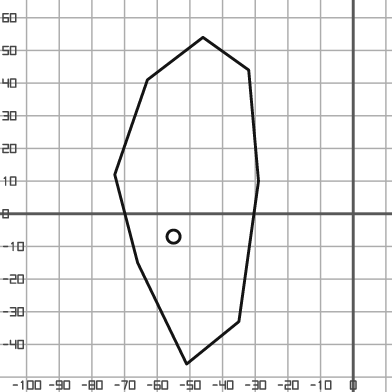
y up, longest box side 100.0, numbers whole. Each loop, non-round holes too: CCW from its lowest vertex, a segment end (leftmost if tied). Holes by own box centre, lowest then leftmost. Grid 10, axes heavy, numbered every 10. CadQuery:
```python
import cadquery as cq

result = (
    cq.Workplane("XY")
    .moveTo(-51.0, -46.0)
    .lineTo(-35.0, -33.0)
    .lineTo(-29.0, 10.0)
    .lineTo(-32.0, 44.0)
    .lineTo(-46.0, 54.0)
    .lineTo(-63.0, 41.0)
    .lineTo(-73.0, 12.0)
    .lineTo(-66.0, -15.0)
    .close()
    .moveTo(-55.0, -7.0)
    .circle(2.0)
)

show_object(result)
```